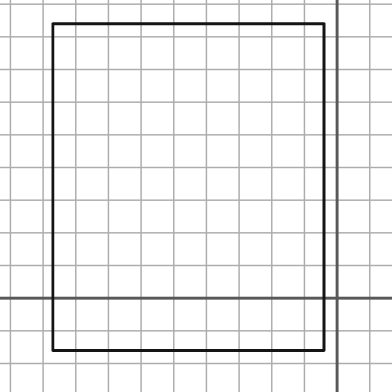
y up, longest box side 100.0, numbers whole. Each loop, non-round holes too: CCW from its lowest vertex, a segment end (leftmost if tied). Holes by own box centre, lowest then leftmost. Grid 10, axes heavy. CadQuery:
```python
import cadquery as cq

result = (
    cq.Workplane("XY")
    .moveTo(-87.0, -16.0)
    .lineTo(-4.0, -16.0)
    .lineTo(-4.0, 84.0)
    .lineTo(-87.0, 84.0)
    .close()
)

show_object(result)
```